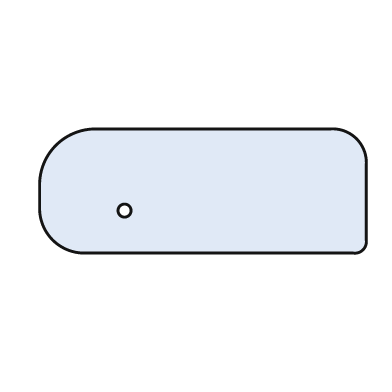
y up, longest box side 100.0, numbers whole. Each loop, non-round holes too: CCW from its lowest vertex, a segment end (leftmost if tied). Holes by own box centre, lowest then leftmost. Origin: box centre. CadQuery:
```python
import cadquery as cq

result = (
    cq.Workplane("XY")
    .moveTo(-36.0, -19.0)
    .lineTo(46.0, -19.0)
    .threePointArc((49.0, -18.0), (50.0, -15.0))
    .lineTo(50.0, 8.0)
    .threePointArc((47.0, 16.0), (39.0, 19.0))
    .lineTo(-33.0, 19.0)
    .threePointArc((-45.0, 14.0), (-50.0, 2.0))
    .lineTo(-50.0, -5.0)
    .threePointArc((-46.0, -15.0), (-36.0, -19.0))
    .close()
    .moveTo(-24.0, -6.0)
    .circle(2.0)
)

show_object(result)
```